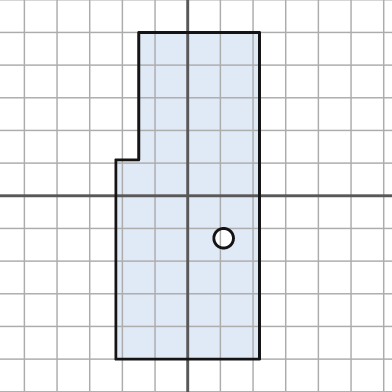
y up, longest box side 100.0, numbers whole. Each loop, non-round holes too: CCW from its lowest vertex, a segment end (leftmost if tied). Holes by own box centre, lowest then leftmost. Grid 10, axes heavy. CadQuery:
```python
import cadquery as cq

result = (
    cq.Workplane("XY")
    .moveTo(-22.0, -50.0)
    .lineTo(22.0, -50.0)
    .lineTo(22.0, 50.0)
    .lineTo(-15.0, 50.0)
    .lineTo(-15.0, 11.0)
    .lineTo(-22.0, 11.0)
    .close()
    .moveTo(11.0, -13.0)
    .circle(3.0)
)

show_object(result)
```